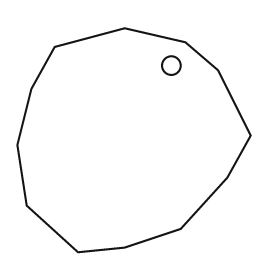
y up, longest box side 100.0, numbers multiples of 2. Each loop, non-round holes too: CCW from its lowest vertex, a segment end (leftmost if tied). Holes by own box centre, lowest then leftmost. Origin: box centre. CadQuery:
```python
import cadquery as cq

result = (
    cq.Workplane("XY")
    .moveTo(-24.0, -48.0)
    .lineTo(-4.0, -46.0)
    .lineTo(20.0, -38.0)
    .lineTo(40.0, -16.0)
    .lineTo(50.0, 2.0)
    .lineTo(36.0, 30.0)
    .lineTo(22.0, 42.0)
    .lineTo(-4.0, 48.0)
    .lineTo(-34.0, 40.0)
    .lineTo(-44.0, 22.0)
    .lineTo(-50.0, -2.0)
    .lineTo(-46.0, -28.0)
    .close()
    .moveTo(16.0, 32.0)
    .circle(4.0)
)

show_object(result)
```